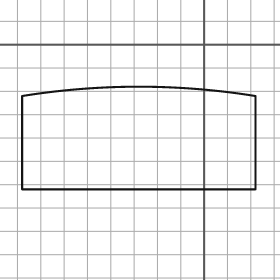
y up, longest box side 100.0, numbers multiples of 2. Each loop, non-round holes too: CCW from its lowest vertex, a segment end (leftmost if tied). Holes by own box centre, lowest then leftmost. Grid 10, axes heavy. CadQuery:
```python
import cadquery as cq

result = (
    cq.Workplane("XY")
    .moveTo(-78.0, -62.0)
    .lineTo(22.0, -62.0)
    .lineTo(22.0, -22.0)
    .threePointArc((-28.0, -18.0), (-78.0, -22.0))
    .close()
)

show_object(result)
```